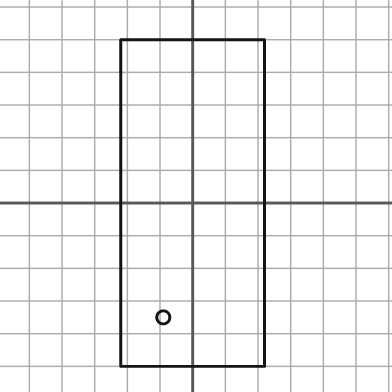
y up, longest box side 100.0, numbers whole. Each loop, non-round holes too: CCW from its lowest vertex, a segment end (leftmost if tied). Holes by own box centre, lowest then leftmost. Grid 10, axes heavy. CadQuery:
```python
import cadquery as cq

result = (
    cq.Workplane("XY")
    .moveTo(-22.0, -50.0)
    .lineTo(22.0, -50.0)
    .lineTo(22.0, 50.0)
    .lineTo(-22.0, 50.0)
    .close()
    .moveTo(-9.0, -35.0)
    .circle(2.0)
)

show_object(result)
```